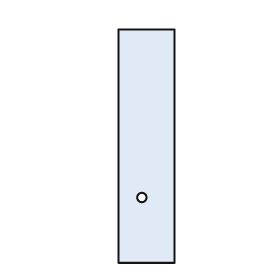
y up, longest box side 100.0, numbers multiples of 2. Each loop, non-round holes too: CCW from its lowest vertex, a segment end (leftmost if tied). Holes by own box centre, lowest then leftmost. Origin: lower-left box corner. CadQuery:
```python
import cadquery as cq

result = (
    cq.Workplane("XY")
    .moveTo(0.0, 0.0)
    .lineTo(24.0, 0.0)
    .lineTo(24.0, 100.0)
    .lineTo(0.0, 100.0)
    .close()
    .moveTo(10.0, 28.0)
    .circle(2.0)
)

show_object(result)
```